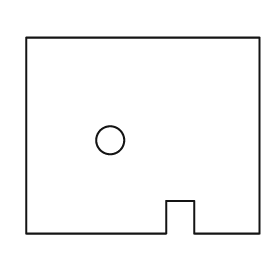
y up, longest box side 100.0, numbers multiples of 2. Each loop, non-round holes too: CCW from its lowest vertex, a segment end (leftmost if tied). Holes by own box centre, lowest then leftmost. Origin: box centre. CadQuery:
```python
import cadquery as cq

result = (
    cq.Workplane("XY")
    .moveTo(-50.0, -42.0)
    .lineTo(10.0, -42.0)
    .lineTo(10.0, -28.0)
    .lineTo(22.0, -28.0)
    .lineTo(22.0, -42.0)
    .lineTo(50.0, -42.0)
    .lineTo(50.0, 42.0)
    .lineTo(-50.0, 42.0)
    .close()
    .moveTo(-14.0, -2.0)
    .circle(6.0)
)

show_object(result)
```